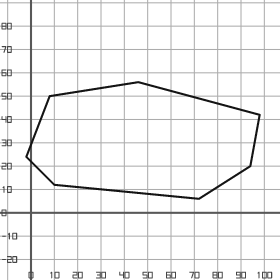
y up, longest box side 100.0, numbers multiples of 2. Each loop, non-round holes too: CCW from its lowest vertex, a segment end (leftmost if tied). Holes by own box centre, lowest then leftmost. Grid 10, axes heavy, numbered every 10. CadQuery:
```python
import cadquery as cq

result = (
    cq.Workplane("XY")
    .moveTo(72.0, 6.0)
    .lineTo(94.0, 20.0)
    .lineTo(98.0, 42.0)
    .lineTo(46.0, 56.0)
    .lineTo(8.0, 50.0)
    .lineTo(-2.0, 24.0)
    .lineTo(10.0, 12.0)
    .close()
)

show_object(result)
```